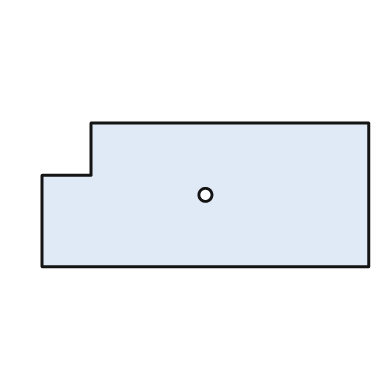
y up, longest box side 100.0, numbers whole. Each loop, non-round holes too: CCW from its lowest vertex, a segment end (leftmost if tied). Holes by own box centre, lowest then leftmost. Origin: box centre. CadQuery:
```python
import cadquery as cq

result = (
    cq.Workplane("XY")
    .moveTo(-50.0, -22.0)
    .lineTo(50.0, -22.0)
    .lineTo(50.0, 22.0)
    .lineTo(-35.0, 22.0)
    .lineTo(-35.0, 6.0)
    .lineTo(-50.0, 6.0)
    .close()
    .moveTo(0.0, 0.0)
    .circle(2.0)
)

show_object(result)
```